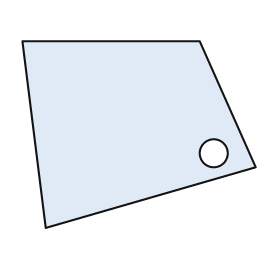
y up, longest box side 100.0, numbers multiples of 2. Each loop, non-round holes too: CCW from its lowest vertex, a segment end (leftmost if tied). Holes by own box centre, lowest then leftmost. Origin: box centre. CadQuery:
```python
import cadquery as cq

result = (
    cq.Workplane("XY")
    .moveTo(-40.0, -40.0)
    .lineTo(50.0, -14.0)
    .lineTo(26.0, 40.0)
    .lineTo(-50.0, 40.0)
    .close()
    .moveTo(32.0, -8.0)
    .circle(6.0)
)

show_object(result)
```